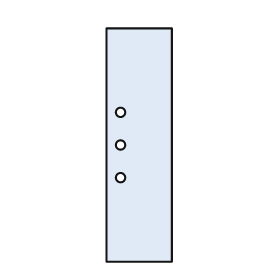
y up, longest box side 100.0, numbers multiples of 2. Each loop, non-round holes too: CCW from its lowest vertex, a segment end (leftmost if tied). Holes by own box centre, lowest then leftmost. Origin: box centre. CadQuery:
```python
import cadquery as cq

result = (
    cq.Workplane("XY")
    .moveTo(-14.0, -50.0)
    .lineTo(14.0, -50.0)
    .lineTo(14.0, 50.0)
    .lineTo(-14.0, 50.0)
    .close()
    .moveTo(-8.0, -14.0)
    .circle(2.0)
    .moveTo(-8.0, 0.0)
    .circle(2.0)
    .moveTo(-8.0, 14.0)
    .circle(2.0)
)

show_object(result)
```